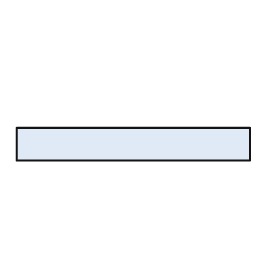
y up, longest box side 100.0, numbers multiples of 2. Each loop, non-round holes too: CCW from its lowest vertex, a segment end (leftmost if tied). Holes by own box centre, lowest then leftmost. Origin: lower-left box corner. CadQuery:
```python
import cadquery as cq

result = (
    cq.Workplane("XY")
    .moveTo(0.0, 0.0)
    .lineTo(100.0, 0.0)
    .lineTo(100.0, 14.0)
    .lineTo(0.0, 14.0)
    .close()
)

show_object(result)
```